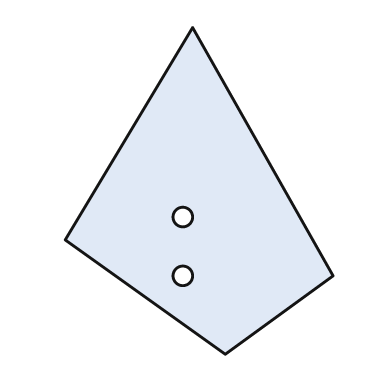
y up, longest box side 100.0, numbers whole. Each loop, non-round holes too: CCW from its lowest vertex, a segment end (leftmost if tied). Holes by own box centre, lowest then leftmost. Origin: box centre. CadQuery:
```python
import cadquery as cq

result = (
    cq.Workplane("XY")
    .moveTo(8.0, -50.0)
    .lineTo(41.0, -26.0)
    .lineTo(-2.0, 50.0)
    .lineTo(-41.0, -15.0)
    .close()
    .moveTo(-5.0, -26.0)
    .circle(3.0)
    .moveTo(-5.0, -8.0)
    .circle(3.0)
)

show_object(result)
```